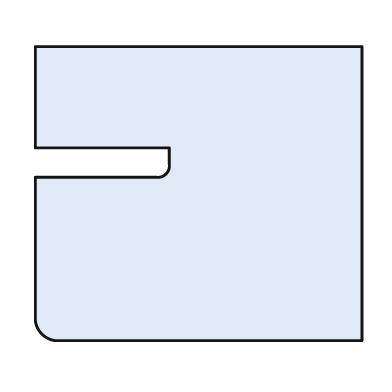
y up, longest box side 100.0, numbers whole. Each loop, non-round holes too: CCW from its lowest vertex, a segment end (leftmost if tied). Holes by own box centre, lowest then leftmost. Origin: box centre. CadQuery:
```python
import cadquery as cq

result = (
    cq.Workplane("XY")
    .moveTo(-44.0, -45.0)
    .lineTo(50.0, -45.0)
    .lineTo(50.0, 45.0)
    .lineTo(-50.0, 45.0)
    .lineTo(-50.0, 14.0)
    .lineTo(-9.0, 14.0)
    .lineTo(-9.0, 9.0)
    .threePointArc((-10.0, 6.0), (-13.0, 5.0))
    .lineTo(-50.0, 5.0)
    .lineTo(-50.0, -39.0)
    .threePointArc((-48.0, -43.0), (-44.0, -45.0))
    .close()
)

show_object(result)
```